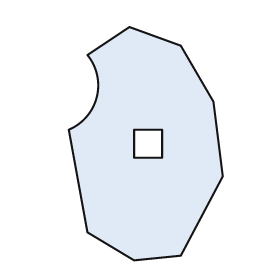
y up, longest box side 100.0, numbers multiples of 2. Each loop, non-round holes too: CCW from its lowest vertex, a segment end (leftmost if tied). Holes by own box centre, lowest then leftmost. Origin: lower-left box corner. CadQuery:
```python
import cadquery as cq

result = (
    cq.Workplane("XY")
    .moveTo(28.0, 0.0)
    .lineTo(48.0, 2.0)
    .lineTo(66.0, 36.0)
    .lineTo(62.0, 68.0)
    .lineTo(48.0, 92.0)
    .lineTo(26.0, 100.0)
    .lineTo(8.0, 88.0)
    .threePointArc((12.0, 70.0), (0.0, 56.0))
    .lineTo(8.0, 12.0)
    .close()
    .moveTo(28.0, 44.0)
    .lineTo(40.0, 44.0)
    .lineTo(40.0, 56.0)
    .lineTo(28.0, 56.0)
    .close()
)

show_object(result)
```